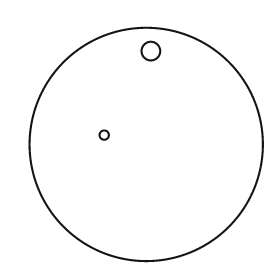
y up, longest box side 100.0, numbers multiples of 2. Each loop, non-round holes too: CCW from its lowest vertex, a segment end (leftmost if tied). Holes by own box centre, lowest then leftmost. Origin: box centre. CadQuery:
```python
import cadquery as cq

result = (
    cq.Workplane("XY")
    .moveTo(0.0, 0.0)
    .circle(50.0)
    .moveTo(-18.0, 4.0)
    .circle(2.0)
    .moveTo(2.0, 40.0)
    .circle(4.0)
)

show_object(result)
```